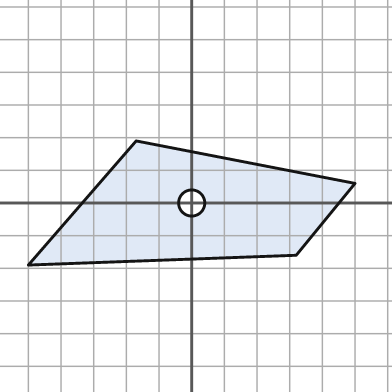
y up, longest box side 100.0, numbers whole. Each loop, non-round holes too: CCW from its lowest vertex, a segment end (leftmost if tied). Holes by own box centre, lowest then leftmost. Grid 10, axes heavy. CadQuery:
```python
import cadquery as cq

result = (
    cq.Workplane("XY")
    .moveTo(-50.0, -19.0)
    .lineTo(32.0, -16.0)
    .lineTo(50.0, 6.0)
    .lineTo(-17.0, 19.0)
    .close()
    .moveTo(0.0, 0.0)
    .circle(4.0)
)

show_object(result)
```